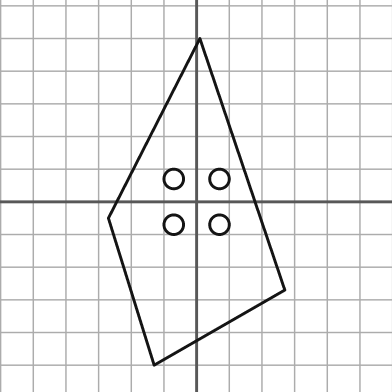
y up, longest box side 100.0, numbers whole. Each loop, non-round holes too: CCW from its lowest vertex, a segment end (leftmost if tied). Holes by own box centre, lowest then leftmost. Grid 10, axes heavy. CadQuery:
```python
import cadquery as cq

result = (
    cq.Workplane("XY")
    .moveTo(-13.0, -50.0)
    .lineTo(27.0, -27.0)
    .lineTo(1.0, 50.0)
    .lineTo(-27.0, -5.0)
    .close()
    .moveTo(-7.0, -7.0)
    .circle(3.0)
    .moveTo(7.0, -7.0)
    .circle(3.0)
    .moveTo(-7.0, 7.0)
    .circle(3.0)
    .moveTo(7.0, 7.0)
    .circle(3.0)
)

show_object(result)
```